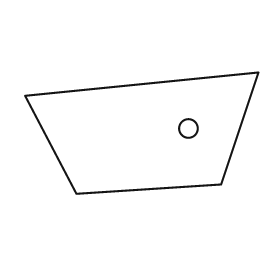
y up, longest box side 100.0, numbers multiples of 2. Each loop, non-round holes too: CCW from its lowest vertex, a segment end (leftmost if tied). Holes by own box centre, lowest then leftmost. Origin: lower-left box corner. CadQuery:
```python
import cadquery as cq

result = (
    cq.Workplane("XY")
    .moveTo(22.0, 0.0)
    .lineTo(84.0, 4.0)
    .lineTo(100.0, 52.0)
    .lineTo(0.0, 42.0)
    .close()
    .moveTo(70.0, 28.0)
    .circle(4.0)
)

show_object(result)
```